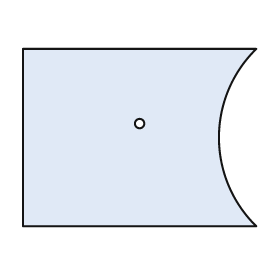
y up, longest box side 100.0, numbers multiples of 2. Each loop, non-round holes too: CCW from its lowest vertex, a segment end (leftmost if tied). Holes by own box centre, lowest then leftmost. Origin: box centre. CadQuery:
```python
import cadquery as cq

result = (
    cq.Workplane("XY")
    .moveTo(-50.0, -38.0)
    .lineTo(50.0, -38.0)
    .threePointArc((34.0, 0.0), (50.0, 38.0))
    .lineTo(-50.0, 38.0)
    .close()
    .moveTo(0.0, 6.0)
    .circle(2.0)
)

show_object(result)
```